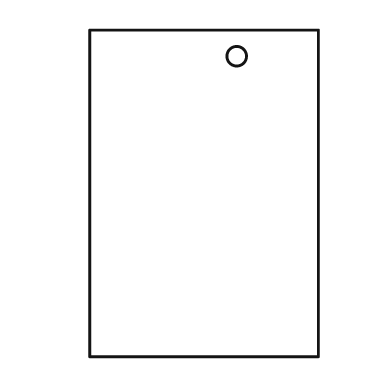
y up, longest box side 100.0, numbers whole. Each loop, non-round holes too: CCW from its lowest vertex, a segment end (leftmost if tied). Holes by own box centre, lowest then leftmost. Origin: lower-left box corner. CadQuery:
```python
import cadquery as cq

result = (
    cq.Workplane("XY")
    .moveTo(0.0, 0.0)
    .lineTo(70.0, 0.0)
    .lineTo(70.0, 100.0)
    .lineTo(0.0, 100.0)
    .close()
    .moveTo(45.0, 92.0)
    .circle(3.0)
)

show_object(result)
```